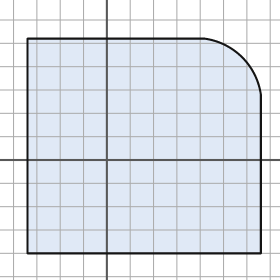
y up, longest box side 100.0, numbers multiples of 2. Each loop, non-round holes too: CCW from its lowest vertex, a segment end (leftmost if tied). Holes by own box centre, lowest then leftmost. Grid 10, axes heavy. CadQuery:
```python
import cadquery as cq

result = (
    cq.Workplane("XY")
    .moveTo(-34.0, -40.0)
    .lineTo(66.0, -40.0)
    .lineTo(66.0, 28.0)
    .threePointArc((58.0, 44.0), (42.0, 52.0))
    .lineTo(-34.0, 52.0)
    .close()
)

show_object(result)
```